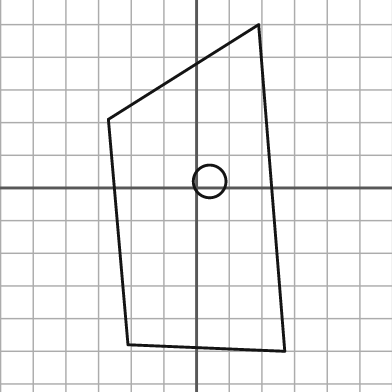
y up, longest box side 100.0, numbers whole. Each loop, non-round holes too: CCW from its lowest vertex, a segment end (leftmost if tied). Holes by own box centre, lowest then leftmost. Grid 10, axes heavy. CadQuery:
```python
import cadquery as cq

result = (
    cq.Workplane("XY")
    .moveTo(27.0, -50.0)
    .lineTo(19.0, 50.0)
    .lineTo(-27.0, 21.0)
    .lineTo(-21.0, -48.0)
    .close()
    .moveTo(4.0, 2.0)
    .circle(5.0)
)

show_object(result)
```